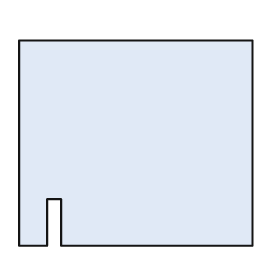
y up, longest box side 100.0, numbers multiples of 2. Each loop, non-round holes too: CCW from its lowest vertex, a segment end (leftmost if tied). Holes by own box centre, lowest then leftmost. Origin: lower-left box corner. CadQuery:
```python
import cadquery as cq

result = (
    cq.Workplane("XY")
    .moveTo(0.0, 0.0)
    .lineTo(12.0, 0.0)
    .lineTo(12.0, 20.0)
    .lineTo(18.0, 20.0)
    .lineTo(18.0, 0.0)
    .lineTo(100.0, 0.0)
    .lineTo(100.0, 88.0)
    .lineTo(0.0, 88.0)
    .close()
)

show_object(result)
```